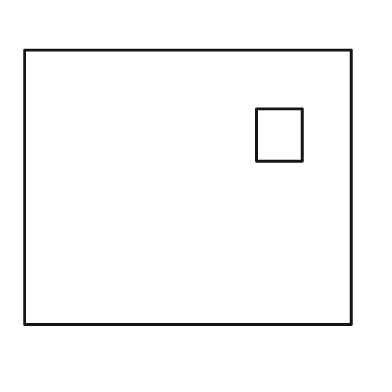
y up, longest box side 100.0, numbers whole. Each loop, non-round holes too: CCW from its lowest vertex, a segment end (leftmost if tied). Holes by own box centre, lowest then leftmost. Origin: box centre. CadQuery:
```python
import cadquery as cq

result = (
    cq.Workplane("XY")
    .moveTo(-50.0, -42.0)
    .lineTo(50.0, -42.0)
    .lineTo(50.0, 42.0)
    .lineTo(-50.0, 42.0)
    .close()
    .moveTo(21.0, 8.0)
    .lineTo(35.0, 8.0)
    .lineTo(35.0, 24.0)
    .lineTo(21.0, 24.0)
    .close()
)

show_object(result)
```